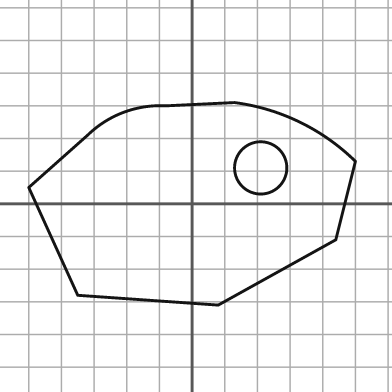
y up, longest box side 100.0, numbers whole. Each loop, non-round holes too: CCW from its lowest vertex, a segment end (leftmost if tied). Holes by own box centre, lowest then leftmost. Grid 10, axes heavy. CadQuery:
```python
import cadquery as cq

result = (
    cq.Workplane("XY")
    .moveTo(8.0, -31.0)
    .lineTo(44.0, -11.0)
    .lineTo(50.0, 13.0)
    .threePointArc((33.0, 25.0), (13.0, 31.0))
    .lineTo(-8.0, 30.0)
    .threePointArc((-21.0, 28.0), (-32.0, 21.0))
    .lineTo(-50.0, 5.0)
    .lineTo(-35.0, -28.0)
    .close()
    .moveTo(21.0, 11.0)
    .circle(8.0)
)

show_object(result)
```